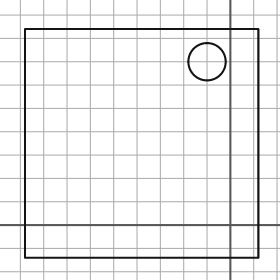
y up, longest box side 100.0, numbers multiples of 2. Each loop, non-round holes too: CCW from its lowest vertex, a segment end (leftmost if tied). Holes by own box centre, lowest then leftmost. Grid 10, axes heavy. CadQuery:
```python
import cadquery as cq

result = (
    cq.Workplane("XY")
    .moveTo(-88.0, -14.0)
    .lineTo(12.0, -14.0)
    .lineTo(12.0, 84.0)
    .lineTo(-88.0, 84.0)
    .close()
    .moveTo(-10.0, 70.0)
    .circle(8.0)
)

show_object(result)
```